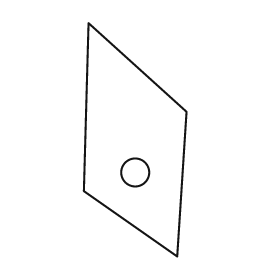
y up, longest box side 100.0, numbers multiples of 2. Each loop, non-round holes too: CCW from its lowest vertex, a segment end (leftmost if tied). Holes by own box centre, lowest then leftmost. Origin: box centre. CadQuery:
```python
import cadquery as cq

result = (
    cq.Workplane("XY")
    .moveTo(18.0, -50.0)
    .lineTo(22.0, 12.0)
    .lineTo(-20.0, 50.0)
    .lineTo(-22.0, -22.0)
    .close()
    .moveTo(0.0, -14.0)
    .circle(6.0)
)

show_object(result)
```